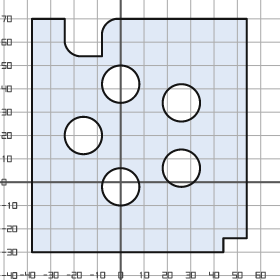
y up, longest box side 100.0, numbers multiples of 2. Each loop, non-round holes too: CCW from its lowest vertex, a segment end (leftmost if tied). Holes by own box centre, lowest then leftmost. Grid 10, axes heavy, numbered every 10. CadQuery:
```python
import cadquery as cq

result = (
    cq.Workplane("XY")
    .moveTo(-38.0, -30.0)
    .lineTo(44.0, -30.0)
    .lineTo(44.0, -24.0)
    .lineTo(54.0, -24.0)
    .lineTo(54.0, 70.0)
    .lineTo(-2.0, 70.0)
    .threePointArc((-6.0, 68.0), (-8.0, 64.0))
    .lineTo(-8.0, 54.0)
    .lineTo(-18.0, 54.0)
    .threePointArc((-22.0, 56.0), (-24.0, 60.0))
    .lineTo(-24.0, 70.0)
    .lineTo(-38.0, 70.0)
    .close()
    .moveTo(0.0, -2.0)
    .circle(8.0)
    .moveTo(26.0, 6.0)
    .circle(8.0)
    .moveTo(-16.0, 20.0)
    .circle(8.0)
    .moveTo(26.0, 34.0)
    .circle(8.0)
    .moveTo(0.0, 42.0)
    .circle(8.0)
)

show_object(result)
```